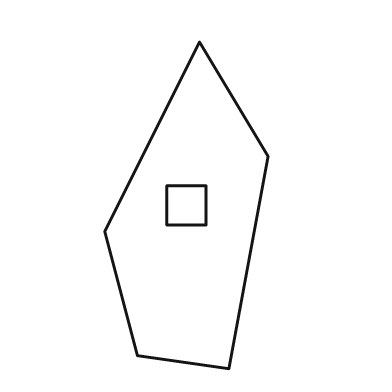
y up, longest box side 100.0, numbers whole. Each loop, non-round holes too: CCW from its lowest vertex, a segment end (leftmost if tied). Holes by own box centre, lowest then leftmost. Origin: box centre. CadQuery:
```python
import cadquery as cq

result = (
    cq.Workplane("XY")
    .moveTo(13.0, -50.0)
    .lineTo(25.0, 15.0)
    .lineTo(4.0, 50.0)
    .lineTo(-25.0, -8.0)
    .lineTo(-15.0, -46.0)
    .close()
    .moveTo(-6.0, -6.0)
    .lineTo(6.0, -6.0)
    .lineTo(6.0, 6.0)
    .lineTo(-6.0, 6.0)
    .close()
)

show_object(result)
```